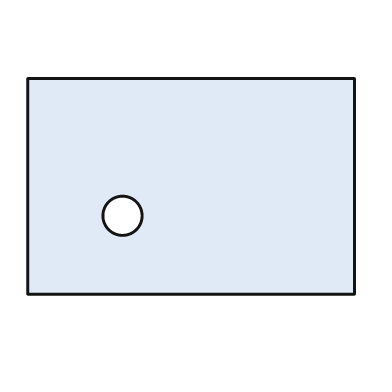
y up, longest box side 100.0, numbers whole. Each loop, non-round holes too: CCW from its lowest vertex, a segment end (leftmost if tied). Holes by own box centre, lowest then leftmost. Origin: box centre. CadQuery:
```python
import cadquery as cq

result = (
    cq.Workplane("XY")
    .moveTo(-50.0, -33.0)
    .lineTo(50.0, -33.0)
    .lineTo(50.0, 33.0)
    .lineTo(-50.0, 33.0)
    .close()
    .moveTo(-21.0, -9.0)
    .circle(6.0)
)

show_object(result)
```